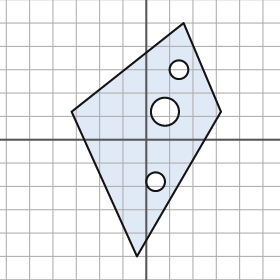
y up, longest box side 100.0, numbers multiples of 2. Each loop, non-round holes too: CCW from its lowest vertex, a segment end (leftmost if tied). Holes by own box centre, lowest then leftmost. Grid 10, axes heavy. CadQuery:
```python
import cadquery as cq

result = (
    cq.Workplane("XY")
    .moveTo(-4.0, -50.0)
    .lineTo(32.0, 12.0)
    .lineTo(16.0, 50.0)
    .lineTo(-32.0, 12.0)
    .close()
    .moveTo(4.0, -18.0)
    .circle(4.0)
    .moveTo(8.0, 12.0)
    .circle(6.0)
    .moveTo(14.0, 30.0)
    .circle(4.0)
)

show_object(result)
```